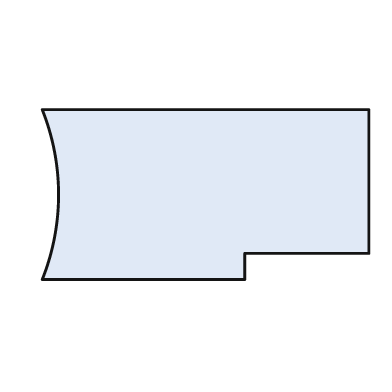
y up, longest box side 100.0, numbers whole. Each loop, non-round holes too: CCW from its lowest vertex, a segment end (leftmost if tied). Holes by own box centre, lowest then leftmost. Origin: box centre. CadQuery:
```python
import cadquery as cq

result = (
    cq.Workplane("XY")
    .moveTo(-50.0, -26.0)
    .lineTo(12.0, -26.0)
    .lineTo(12.0, -18.0)
    .lineTo(50.0, -18.0)
    .lineTo(50.0, 26.0)
    .lineTo(-50.0, 26.0)
    .threePointArc((-45.0, 0.0), (-50.0, -26.0))
    .close()
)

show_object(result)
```